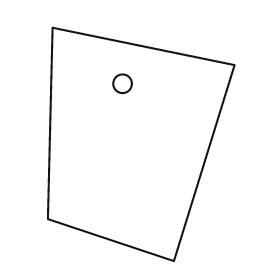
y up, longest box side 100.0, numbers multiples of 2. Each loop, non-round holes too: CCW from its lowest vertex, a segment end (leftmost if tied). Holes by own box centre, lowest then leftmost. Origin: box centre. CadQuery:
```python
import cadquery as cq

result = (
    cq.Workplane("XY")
    .moveTo(14.0, -50.0)
    .lineTo(40.0, 34.0)
    .lineTo(-38.0, 50.0)
    .lineTo(-40.0, -32.0)
    .close()
    .moveTo(-8.0, 26.0)
    .circle(4.0)
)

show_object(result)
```